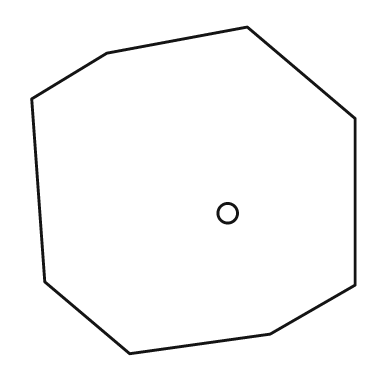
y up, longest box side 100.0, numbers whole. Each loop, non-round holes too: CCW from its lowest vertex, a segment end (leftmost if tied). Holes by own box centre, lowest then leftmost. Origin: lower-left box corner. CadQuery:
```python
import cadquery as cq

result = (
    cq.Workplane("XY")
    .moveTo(30.0, 0.0)
    .lineTo(73.0, 6.0)
    .lineTo(99.0, 21.0)
    .lineTo(99.0, 72.0)
    .lineTo(66.0, 100.0)
    .lineTo(23.0, 92.0)
    .lineTo(0.0, 78.0)
    .lineTo(4.0, 22.0)
    .close()
    .moveTo(60.0, 43.0)
    .circle(3.0)
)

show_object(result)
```